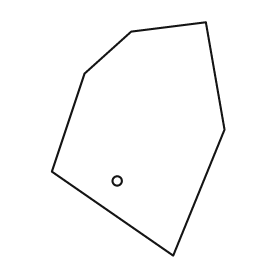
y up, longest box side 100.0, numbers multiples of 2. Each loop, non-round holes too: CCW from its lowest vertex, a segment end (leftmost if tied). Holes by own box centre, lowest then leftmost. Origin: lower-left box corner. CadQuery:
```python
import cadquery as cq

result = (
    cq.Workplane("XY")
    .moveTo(52.0, 0.0)
    .lineTo(74.0, 54.0)
    .lineTo(66.0, 100.0)
    .lineTo(34.0, 96.0)
    .lineTo(14.0, 78.0)
    .lineTo(0.0, 36.0)
    .close()
    .moveTo(28.0, 32.0)
    .circle(2.0)
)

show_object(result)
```